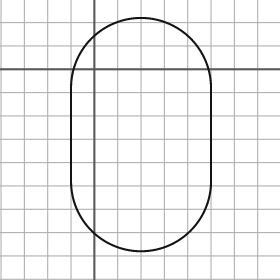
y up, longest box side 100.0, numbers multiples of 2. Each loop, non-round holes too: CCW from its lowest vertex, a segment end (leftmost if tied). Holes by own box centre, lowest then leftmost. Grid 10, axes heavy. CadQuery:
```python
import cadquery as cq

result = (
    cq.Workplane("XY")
    .moveTo(-10.0, -48.0)
    .threePointArc((20.0, -78.0), (50.0, -48.0))
    .lineTo(50.0, -8.0)
    .threePointArc((20.0, 22.0), (-10.0, -8.0))
    .close()
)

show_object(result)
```